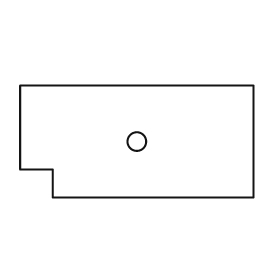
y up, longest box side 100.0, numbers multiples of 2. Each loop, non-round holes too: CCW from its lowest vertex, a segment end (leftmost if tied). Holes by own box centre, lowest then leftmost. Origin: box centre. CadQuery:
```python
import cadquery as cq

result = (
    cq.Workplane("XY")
    .moveTo(-36.0, -24.0)
    .lineTo(50.0, -24.0)
    .lineTo(50.0, 24.0)
    .lineTo(-50.0, 24.0)
    .lineTo(-50.0, -12.0)
    .lineTo(-36.0, -12.0)
    .close()
    .moveTo(0.0, 0.0)
    .circle(4.0)
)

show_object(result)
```